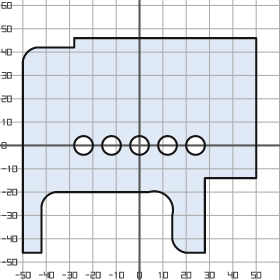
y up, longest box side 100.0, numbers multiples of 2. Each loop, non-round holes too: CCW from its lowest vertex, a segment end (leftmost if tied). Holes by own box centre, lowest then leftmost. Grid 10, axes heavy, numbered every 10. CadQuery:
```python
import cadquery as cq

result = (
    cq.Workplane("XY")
    .moveTo(-50.0, -46.0)
    .lineTo(-42.0, -46.0)
    .lineTo(-42.0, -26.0)
    .threePointArc((-40.0, -22.0), (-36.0, -20.0))
    .lineTo(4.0, -20.0)
    .threePointArc((12.0, -22.0), (14.0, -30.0))
    .lineTo(14.0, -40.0)
    .threePointArc((16.0, -44.0), (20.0, -46.0))
    .lineTo(28.0, -46.0)
    .lineTo(28.0, -14.0)
    .lineTo(50.0, -14.0)
    .lineTo(50.0, 46.0)
    .lineTo(-28.0, 46.0)
    .lineTo(-28.0, 42.0)
    .lineTo(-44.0, 42.0)
    .threePointArc((-48.0, 40.0), (-50.0, 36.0))
    .close()
    .moveTo(-24.0, 0.0)
    .circle(4.0)
    .moveTo(-12.0, 0.0)
    .circle(4.0)
    .moveTo(0.0, 0.0)
    .circle(4.0)
    .moveTo(12.0, 0.0)
    .circle(4.0)
    .moveTo(24.0, 0.0)
    .circle(4.0)
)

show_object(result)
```